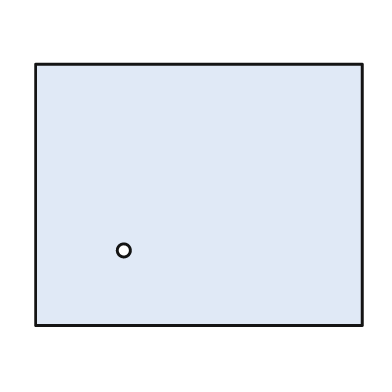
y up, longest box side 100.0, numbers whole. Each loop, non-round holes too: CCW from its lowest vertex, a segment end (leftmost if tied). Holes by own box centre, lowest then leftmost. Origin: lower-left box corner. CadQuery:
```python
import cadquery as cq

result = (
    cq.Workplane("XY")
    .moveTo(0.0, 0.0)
    .lineTo(100.0, 0.0)
    .lineTo(100.0, 80.0)
    .lineTo(0.0, 80.0)
    .close()
    .moveTo(27.0, 23.0)
    .circle(2.0)
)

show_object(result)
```